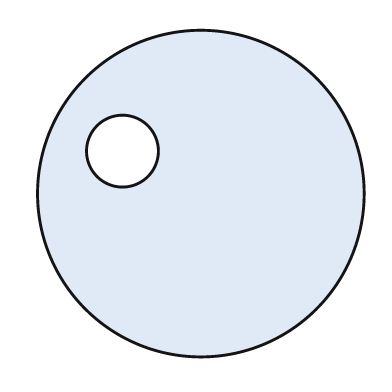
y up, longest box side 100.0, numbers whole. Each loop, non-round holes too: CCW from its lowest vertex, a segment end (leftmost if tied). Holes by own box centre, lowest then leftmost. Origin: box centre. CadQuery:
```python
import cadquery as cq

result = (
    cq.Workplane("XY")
    .moveTo(0.0, 0.0)
    .circle(50.0)
    .moveTo(-24.0, 13.0)
    .circle(11.0)
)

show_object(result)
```